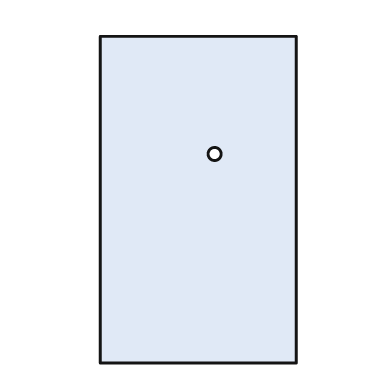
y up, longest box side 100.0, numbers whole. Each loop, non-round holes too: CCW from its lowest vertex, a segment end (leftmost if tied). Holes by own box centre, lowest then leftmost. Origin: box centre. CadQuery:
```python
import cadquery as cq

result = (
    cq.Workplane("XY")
    .moveTo(-30.0, -50.0)
    .lineTo(30.0, -50.0)
    .lineTo(30.0, 50.0)
    .lineTo(-30.0, 50.0)
    .close()
    .moveTo(5.0, 14.0)
    .circle(2.0)
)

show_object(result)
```